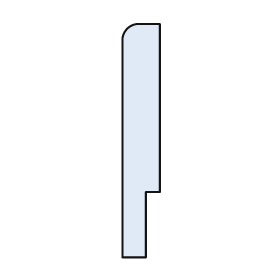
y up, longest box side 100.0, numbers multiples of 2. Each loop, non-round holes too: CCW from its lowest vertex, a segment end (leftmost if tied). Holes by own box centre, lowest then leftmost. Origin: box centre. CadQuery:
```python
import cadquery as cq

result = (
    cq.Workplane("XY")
    .moveTo(-8.0, -50.0)
    .lineTo(2.0, -50.0)
    .lineTo(2.0, -22.0)
    .lineTo(8.0, -22.0)
    .lineTo(8.0, 50.0)
    .lineTo(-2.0, 50.0)
    .threePointArc((-6.0, 48.0), (-8.0, 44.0))
    .close()
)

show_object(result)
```